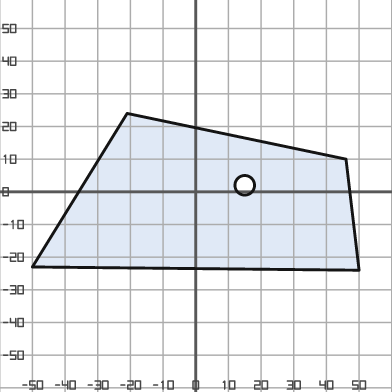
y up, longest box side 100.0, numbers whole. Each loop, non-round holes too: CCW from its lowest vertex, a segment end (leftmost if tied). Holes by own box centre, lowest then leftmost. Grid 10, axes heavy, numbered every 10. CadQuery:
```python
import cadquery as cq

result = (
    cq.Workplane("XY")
    .moveTo(50.0, -24.0)
    .lineTo(46.0, 10.0)
    .lineTo(-21.0, 24.0)
    .lineTo(-50.0, -23.0)
    .close()
    .moveTo(15.0, 2.0)
    .circle(3.0)
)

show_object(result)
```